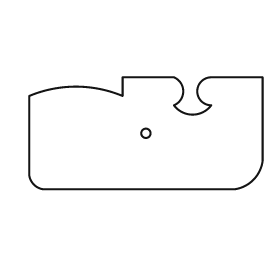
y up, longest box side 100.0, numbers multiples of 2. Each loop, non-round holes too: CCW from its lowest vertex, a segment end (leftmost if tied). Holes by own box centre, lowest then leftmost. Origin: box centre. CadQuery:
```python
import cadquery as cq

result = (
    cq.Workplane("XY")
    .moveTo(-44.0, -24.0)
    .lineTo(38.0, -24.0)
    .threePointArc((46.0, -20.0), (50.0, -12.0))
    .lineTo(50.0, 24.0)
    .lineTo(28.0, 24.0)
    .threePointArc((22.0, 18.0), (28.0, 12.0))
    .threePointArc((20.0, 8.0), (12.0, 12.0))
    .threePointArc((16.0, 18.0), (12.0, 24.0))
    .lineTo(-10.0, 24.0)
    .lineTo(-10.0, 16.0)
    .threePointArc((-30.0, 20.0), (-50.0, 16.0))
    .lineTo(-50.0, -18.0)
    .threePointArc((-48.0, -22.0), (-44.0, -24.0))
    .close()
    .moveTo(0.0, 0.0)
    .circle(2.0)
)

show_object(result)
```